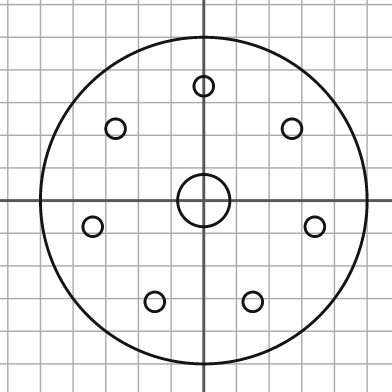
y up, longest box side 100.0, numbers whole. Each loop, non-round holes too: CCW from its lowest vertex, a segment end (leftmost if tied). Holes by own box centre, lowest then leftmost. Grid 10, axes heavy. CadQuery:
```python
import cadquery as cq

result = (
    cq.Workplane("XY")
    .moveTo(0.0, 0.0)
    .circle(50.0)
    .moveTo(-15.0, -31.0)
    .circle(3.0)
    .moveTo(15.0, -31.0)
    .circle(3.0)
    .moveTo(-34.0, -8.0)
    .circle(3.0)
    .moveTo(34.0, -8.0)
    .circle(3.0)
    .moveTo(0.0, 0.0)
    .circle(8.0)
    .moveTo(-27.0, 22.0)
    .circle(3.0)
    .moveTo(27.0, 22.0)
    .circle(3.0)
    .moveTo(0.0, 35.0)
    .circle(3.0)
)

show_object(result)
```